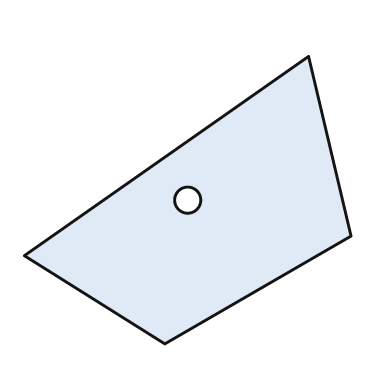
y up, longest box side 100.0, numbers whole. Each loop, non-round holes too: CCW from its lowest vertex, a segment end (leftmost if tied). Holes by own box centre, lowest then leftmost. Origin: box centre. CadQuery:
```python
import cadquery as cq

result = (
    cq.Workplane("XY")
    .moveTo(-7.0, -44.0)
    .lineTo(50.0, -11.0)
    .lineTo(37.0, 44.0)
    .lineTo(-50.0, -17.0)
    .close()
    .moveTo(0.0, 0.0)
    .circle(4.0)
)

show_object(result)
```